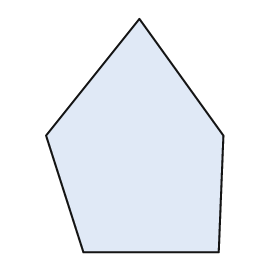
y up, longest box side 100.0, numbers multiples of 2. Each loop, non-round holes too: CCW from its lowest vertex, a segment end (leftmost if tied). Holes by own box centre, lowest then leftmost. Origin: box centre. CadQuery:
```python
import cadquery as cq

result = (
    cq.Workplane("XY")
    .moveTo(-22.0, -50.0)
    .lineTo(36.0, -50.0)
    .lineTo(38.0, 0.0)
    .lineTo(2.0, 50.0)
    .lineTo(-38.0, 0.0)
    .close()
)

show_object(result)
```